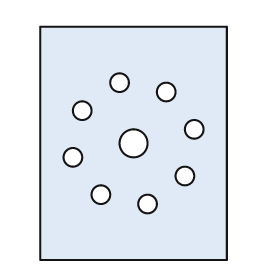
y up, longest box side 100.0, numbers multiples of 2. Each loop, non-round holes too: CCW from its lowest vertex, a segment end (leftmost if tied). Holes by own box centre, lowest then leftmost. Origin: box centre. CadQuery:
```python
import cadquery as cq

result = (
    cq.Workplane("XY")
    .moveTo(-40.0, -50.0)
    .lineTo(40.0, -50.0)
    .lineTo(40.0, 50.0)
    .lineTo(-40.0, 50.0)
    .close()
    .moveTo(6.0, -26.0)
    .circle(4.0)
    .moveTo(-14.0, -22.0)
    .circle(4.0)
    .moveTo(22.0, -14.0)
    .circle(4.0)
    .moveTo(-26.0, -6.0)
    .circle(4.0)
    .moveTo(0.0, 0.0)
    .circle(6.0)
    .moveTo(26.0, 6.0)
    .circle(4.0)
    .moveTo(-22.0, 14.0)
    .circle(4.0)
    .moveTo(14.0, 22.0)
    .circle(4.0)
    .moveTo(-6.0, 26.0)
    .circle(4.0)
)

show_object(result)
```